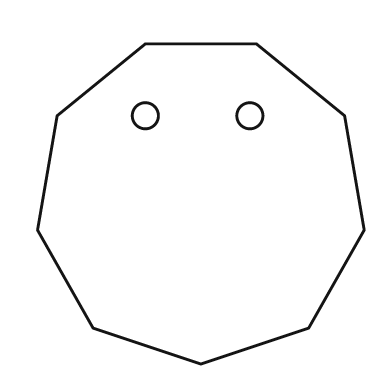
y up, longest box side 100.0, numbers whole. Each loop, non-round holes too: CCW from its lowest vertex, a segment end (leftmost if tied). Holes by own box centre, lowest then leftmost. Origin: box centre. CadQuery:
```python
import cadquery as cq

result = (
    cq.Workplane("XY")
    .moveTo(0.0, -49.0)
    .lineTo(33.0, -38.0)
    .lineTo(50.0, -8.0)
    .lineTo(44.0, 27.0)
    .lineTo(17.0, 49.0)
    .lineTo(-17.0, 49.0)
    .lineTo(-44.0, 27.0)
    .lineTo(-50.0, -8.0)
    .lineTo(-33.0, -38.0)
    .close()
    .moveTo(-17.0, 27.0)
    .circle(4.0)
    .moveTo(15.0, 27.0)
    .circle(4.0)
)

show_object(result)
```